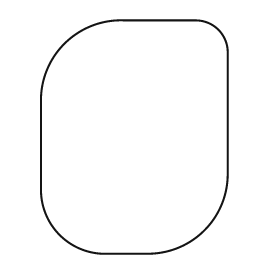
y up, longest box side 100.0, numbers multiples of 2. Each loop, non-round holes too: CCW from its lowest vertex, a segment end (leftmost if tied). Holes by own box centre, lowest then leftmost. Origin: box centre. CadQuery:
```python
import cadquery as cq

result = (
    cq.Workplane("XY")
    .moveTo(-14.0, -50.0)
    .lineTo(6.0, -50.0)
    .threePointArc((30.0, -40.0), (40.0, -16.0))
    .lineTo(40.0, 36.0)
    .threePointArc((36.0, 46.0), (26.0, 50.0))
    .lineTo(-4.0, 50.0)
    .threePointArc((-30.0, 40.0), (-40.0, 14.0))
    .lineTo(-40.0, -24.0)
    .threePointArc((-32.0, -42.0), (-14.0, -50.0))
    .close()
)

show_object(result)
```